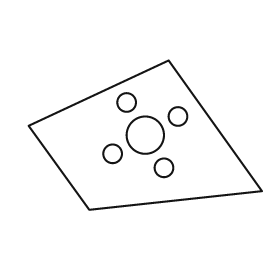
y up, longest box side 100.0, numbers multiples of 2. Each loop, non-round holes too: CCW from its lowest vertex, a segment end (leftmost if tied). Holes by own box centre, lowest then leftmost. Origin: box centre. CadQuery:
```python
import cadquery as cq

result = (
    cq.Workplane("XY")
    .moveTo(-24.0, -32.0)
    .lineTo(50.0, -24.0)
    .lineTo(10.0, 32.0)
    .lineTo(-50.0, 4.0)
    .close()
    .moveTo(8.0, -14.0)
    .circle(4.0)
    .moveTo(-14.0, -8.0)
    .circle(4.0)
    .moveTo(0.0, 0.0)
    .circle(8.0)
    .moveTo(14.0, 8.0)
    .circle(4.0)
    .moveTo(-8.0, 14.0)
    .circle(4.0)
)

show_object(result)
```